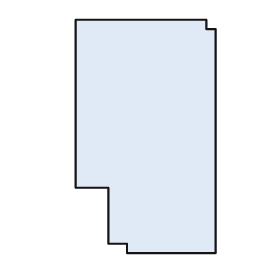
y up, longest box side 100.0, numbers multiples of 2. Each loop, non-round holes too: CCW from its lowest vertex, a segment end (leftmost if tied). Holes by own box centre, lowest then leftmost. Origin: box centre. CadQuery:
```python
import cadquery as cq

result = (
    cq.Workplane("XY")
    .moveTo(-8.0, -50.0)
    .lineTo(30.0, -50.0)
    .lineTo(30.0, 46.0)
    .lineTo(26.0, 46.0)
    .lineTo(26.0, 50.0)
    .lineTo(-30.0, 50.0)
    .lineTo(-30.0, -22.0)
    .lineTo(-16.0, -22.0)
    .lineTo(-16.0, -46.0)
    .lineTo(-8.0, -46.0)
    .close()
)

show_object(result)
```